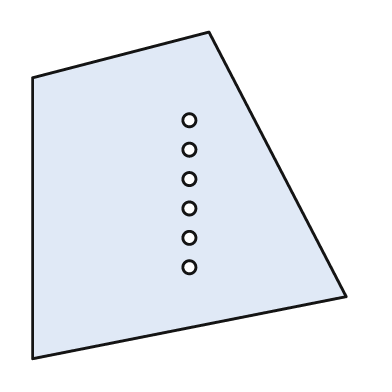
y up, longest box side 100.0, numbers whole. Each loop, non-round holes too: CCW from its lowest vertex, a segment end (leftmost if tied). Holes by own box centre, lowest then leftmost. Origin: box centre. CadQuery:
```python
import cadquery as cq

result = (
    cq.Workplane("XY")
    .moveTo(-48.0, -50.0)
    .lineTo(48.0, -31.0)
    .lineTo(6.0, 50.0)
    .lineTo(-48.0, 36.0)
    .close()
    .moveTo(0.0, -22.0)
    .circle(2.0)
    .moveTo(0.0, -13.0)
    .circle(2.0)
    .moveTo(0.0, -4.0)
    .circle(2.0)
    .moveTo(0.0, 5.0)
    .circle(2.0)
    .moveTo(0.0, 14.0)
    .circle(2.0)
    .moveTo(0.0, 23.0)
    .circle(2.0)
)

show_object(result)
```